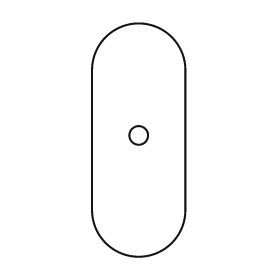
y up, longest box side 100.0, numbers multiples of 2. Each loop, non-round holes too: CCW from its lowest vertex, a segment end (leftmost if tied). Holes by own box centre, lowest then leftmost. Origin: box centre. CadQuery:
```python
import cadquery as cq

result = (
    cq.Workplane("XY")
    .moveTo(-20.0, -30.0)
    .threePointArc((0.0, -50.0), (20.0, -30.0))
    .lineTo(20.0, 30.0)
    .threePointArc((0.0, 50.0), (-20.0, 30.0))
    .close()
    .moveTo(0.0, 2.0)
    .circle(4.0)
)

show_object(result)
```